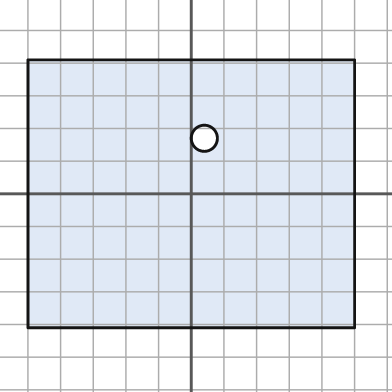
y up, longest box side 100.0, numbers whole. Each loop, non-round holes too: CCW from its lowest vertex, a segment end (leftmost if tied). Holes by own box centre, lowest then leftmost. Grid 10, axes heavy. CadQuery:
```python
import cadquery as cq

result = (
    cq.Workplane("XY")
    .moveTo(-50.0, -41.0)
    .lineTo(50.0, -41.0)
    .lineTo(50.0, 41.0)
    .lineTo(-50.0, 41.0)
    .close()
    .moveTo(4.0, 17.0)
    .circle(4.0)
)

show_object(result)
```